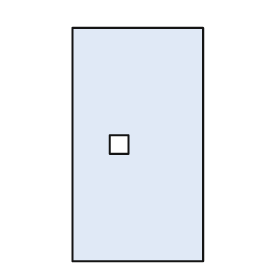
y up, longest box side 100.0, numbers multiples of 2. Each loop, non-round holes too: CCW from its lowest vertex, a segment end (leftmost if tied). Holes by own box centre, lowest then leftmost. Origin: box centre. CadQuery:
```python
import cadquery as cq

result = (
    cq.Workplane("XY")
    .moveTo(-28.0, -50.0)
    .lineTo(28.0, -50.0)
    .lineTo(28.0, 50.0)
    .lineTo(-28.0, 50.0)
    .close()
    .moveTo(-12.0, -4.0)
    .lineTo(-4.0, -4.0)
    .lineTo(-4.0, 4.0)
    .lineTo(-12.0, 4.0)
    .close()
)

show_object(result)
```